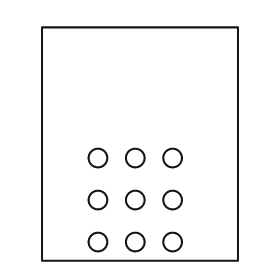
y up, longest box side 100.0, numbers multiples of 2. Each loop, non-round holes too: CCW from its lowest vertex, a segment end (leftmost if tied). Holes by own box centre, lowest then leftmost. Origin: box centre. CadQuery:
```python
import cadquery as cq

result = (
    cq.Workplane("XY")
    .moveTo(-42.0, -50.0)
    .lineTo(42.0, -50.0)
    .lineTo(42.0, 50.0)
    .lineTo(-42.0, 50.0)
    .close()
    .moveTo(-18.0, -42.0)
    .circle(4.0)
    .moveTo(-2.0, -42.0)
    .circle(4.0)
    .moveTo(14.0, -42.0)
    .circle(4.0)
    .moveTo(-18.0, -24.0)
    .circle(4.0)
    .moveTo(-2.0, -24.0)
    .circle(4.0)
    .moveTo(14.0, -24.0)
    .circle(4.0)
    .moveTo(-18.0, -6.0)
    .circle(4.0)
    .moveTo(-2.0, -6.0)
    .circle(4.0)
    .moveTo(14.0, -6.0)
    .circle(4.0)
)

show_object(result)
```